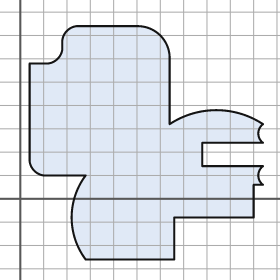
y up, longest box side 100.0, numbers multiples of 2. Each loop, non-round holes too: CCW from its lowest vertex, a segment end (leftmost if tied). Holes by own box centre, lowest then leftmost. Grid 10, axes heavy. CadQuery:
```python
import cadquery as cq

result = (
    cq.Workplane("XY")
    .moveTo(28.0, -26.0)
    .lineTo(66.0, -26.0)
    .lineTo(66.0, -8.0)
    .lineTo(100.0, -8.0)
    .lineTo(100.0, 6.0)
    .lineTo(104.0, 6.0)
    .threePointArc((102.0, 10.0), (104.0, 14.0))
    .lineTo(78.0, 14.0)
    .lineTo(78.0, 24.0)
    .lineTo(104.0, 24.0)
    .threePointArc((102.0, 28.0), (104.0, 32.0))
    .threePointArc((84.0, 38.0), (64.0, 32.0))
    .lineTo(64.0, 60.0)
    .threePointArc((60.0, 70.0), (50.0, 74.0))
    .lineTo(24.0, 74.0)
    .threePointArc((20.0, 72.0), (18.0, 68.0))
    .lineTo(18.0, 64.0)
    .threePointArc((16.0, 60.0), (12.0, 58.0))
    .lineTo(4.0, 58.0)
    .lineTo(4.0, 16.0)
    .threePointArc((6.0, 12.0), (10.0, 10.0))
    .lineTo(28.0, 10.0)
    .threePointArc((22.0, -8.0), (28.0, -26.0))
    .close()
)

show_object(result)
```